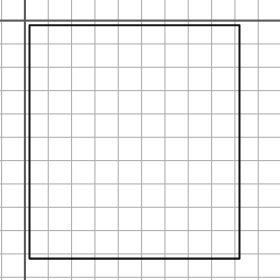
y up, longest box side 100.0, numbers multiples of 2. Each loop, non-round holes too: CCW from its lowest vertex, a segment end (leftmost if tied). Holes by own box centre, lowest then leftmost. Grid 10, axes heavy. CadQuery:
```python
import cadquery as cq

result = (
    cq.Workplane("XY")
    .moveTo(2.0, -102.0)
    .lineTo(92.0, -102.0)
    .lineTo(92.0, -2.0)
    .lineTo(2.0, -2.0)
    .close()
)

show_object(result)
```